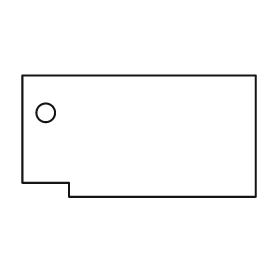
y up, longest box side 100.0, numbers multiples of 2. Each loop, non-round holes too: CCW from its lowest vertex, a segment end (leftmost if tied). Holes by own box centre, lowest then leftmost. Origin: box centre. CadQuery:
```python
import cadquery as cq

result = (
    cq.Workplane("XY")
    .moveTo(-30.0, -26.0)
    .lineTo(50.0, -26.0)
    .lineTo(50.0, 26.0)
    .lineTo(-50.0, 26.0)
    .lineTo(-50.0, -20.0)
    .lineTo(-30.0, -20.0)
    .close()
    .moveTo(-40.0, 10.0)
    .circle(4.0)
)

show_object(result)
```